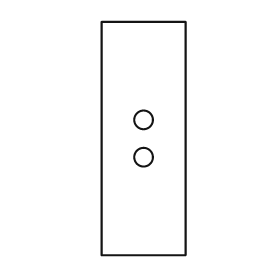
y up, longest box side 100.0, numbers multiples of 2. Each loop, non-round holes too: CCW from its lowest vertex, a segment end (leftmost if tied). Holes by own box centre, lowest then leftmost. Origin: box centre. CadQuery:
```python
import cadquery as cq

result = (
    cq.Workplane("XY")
    .moveTo(-18.0, -50.0)
    .lineTo(18.0, -50.0)
    .lineTo(18.0, 50.0)
    .lineTo(-18.0, 50.0)
    .close()
    .moveTo(0.0, -8.0)
    .circle(4.0)
    .moveTo(0.0, 8.0)
    .circle(4.0)
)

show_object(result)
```